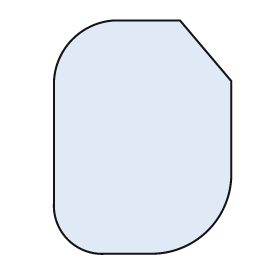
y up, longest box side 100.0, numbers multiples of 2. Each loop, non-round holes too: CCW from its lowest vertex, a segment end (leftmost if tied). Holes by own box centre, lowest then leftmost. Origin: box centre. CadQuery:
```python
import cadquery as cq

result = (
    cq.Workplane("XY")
    .moveTo(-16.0, -50.0)
    .lineTo(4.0, -50.0)
    .threePointArc((28.0, -40.0), (38.0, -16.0))
    .lineTo(38.0, 24.0)
    .lineTo(16.0, 50.0)
    .lineTo(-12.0, 50.0)
    .threePointArc((-30.0, 42.0), (-38.0, 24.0))
    .lineTo(-38.0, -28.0)
    .threePointArc((-32.0, -44.0), (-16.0, -50.0))
    .close()
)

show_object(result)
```